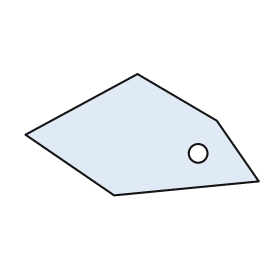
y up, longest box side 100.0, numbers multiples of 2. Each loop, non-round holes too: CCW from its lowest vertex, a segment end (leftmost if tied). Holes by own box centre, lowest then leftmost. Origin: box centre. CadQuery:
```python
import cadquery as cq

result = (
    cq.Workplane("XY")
    .moveTo(-12.0, -26.0)
    .lineTo(50.0, -20.0)
    .lineTo(32.0, 6.0)
    .lineTo(-2.0, 26.0)
    .lineTo(-50.0, 0.0)
    .close()
    .moveTo(24.0, -8.0)
    .circle(4.0)
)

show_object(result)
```